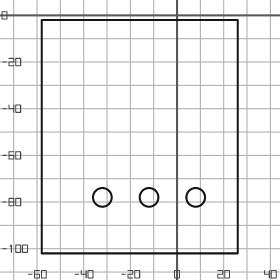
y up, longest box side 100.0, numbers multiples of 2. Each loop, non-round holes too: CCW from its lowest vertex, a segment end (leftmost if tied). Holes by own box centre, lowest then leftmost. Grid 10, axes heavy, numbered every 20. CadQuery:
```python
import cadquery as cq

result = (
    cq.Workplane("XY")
    .moveTo(-58.0, -102.0)
    .lineTo(26.0, -102.0)
    .lineTo(26.0, -2.0)
    .lineTo(-58.0, -2.0)
    .close()
    .moveTo(-32.0, -78.0)
    .circle(4.0)
    .moveTo(-12.0, -78.0)
    .circle(4.0)
    .moveTo(8.0, -78.0)
    .circle(4.0)
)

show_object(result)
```